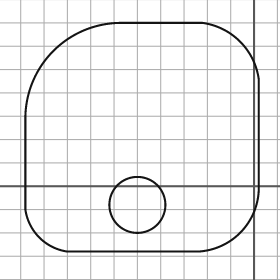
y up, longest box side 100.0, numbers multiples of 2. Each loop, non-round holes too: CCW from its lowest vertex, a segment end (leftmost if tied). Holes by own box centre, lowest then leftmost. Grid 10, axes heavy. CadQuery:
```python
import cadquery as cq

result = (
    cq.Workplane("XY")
    .moveTo(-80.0, -28.0)
    .lineTo(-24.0, -28.0)
    .threePointArc((-6.0, -20.0), (2.0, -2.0))
    .lineTo(2.0, 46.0)
    .threePointArc((-6.0, 62.0), (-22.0, 70.0))
    .lineTo(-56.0, 70.0)
    .threePointArc((-86.0, 58.0), (-98.0, 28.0))
    .lineTo(-98.0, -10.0)
    .threePointArc((-92.0, -22.0), (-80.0, -28.0))
    .close()
    .moveTo(-50.0, -8.0)
    .circle(12.0)
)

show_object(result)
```